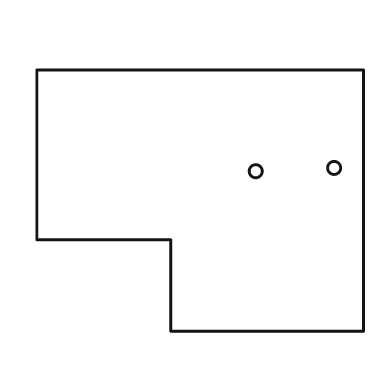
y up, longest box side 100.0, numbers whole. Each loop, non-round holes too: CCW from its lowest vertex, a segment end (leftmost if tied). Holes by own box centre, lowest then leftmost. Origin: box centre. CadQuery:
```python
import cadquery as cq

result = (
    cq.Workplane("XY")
    .moveTo(-9.0, -40.0)
    .lineTo(50.0, -40.0)
    .lineTo(50.0, 40.0)
    .lineTo(-50.0, 40.0)
    .lineTo(-50.0, -12.0)
    .lineTo(-9.0, -12.0)
    .close()
    .moveTo(17.0, 9.0)
    .circle(2.0)
    .moveTo(41.0, 10.0)
    .circle(2.0)
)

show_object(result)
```